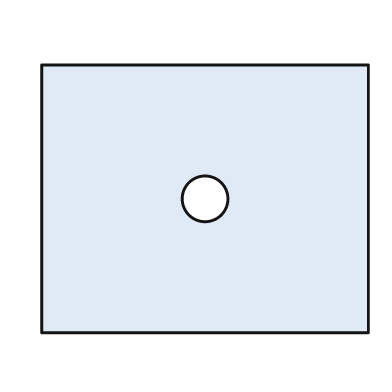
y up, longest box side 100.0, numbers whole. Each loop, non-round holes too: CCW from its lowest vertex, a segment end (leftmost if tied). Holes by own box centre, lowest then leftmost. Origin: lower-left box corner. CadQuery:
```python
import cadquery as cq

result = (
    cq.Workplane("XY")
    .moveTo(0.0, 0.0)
    .lineTo(100.0, 0.0)
    .lineTo(100.0, 82.0)
    .lineTo(0.0, 82.0)
    .close()
    .moveTo(50.0, 41.0)
    .circle(7.0)
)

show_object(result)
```